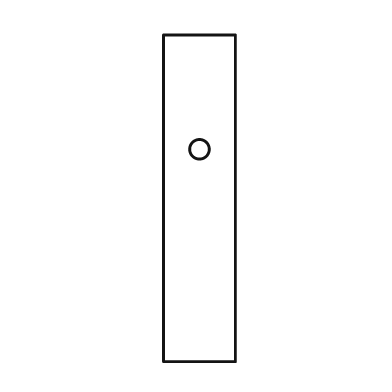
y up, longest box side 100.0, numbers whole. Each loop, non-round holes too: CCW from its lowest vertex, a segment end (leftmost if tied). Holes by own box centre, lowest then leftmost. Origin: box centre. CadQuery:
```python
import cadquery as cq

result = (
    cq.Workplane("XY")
    .moveTo(-11.0, -50.0)
    .lineTo(11.0, -50.0)
    .lineTo(11.0, 50.0)
    .lineTo(-11.0, 50.0)
    .close()
    .moveTo(0.0, 15.0)
    .circle(3.0)
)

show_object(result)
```